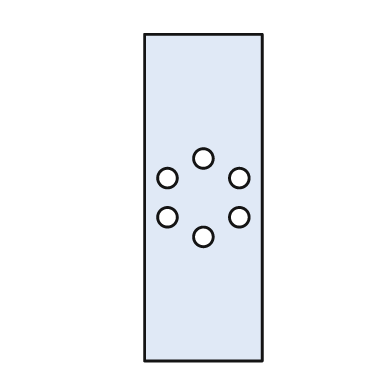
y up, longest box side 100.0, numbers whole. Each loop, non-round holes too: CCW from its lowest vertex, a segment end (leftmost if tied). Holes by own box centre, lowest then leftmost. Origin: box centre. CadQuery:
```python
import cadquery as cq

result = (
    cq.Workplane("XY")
    .moveTo(-18.0, -50.0)
    .lineTo(18.0, -50.0)
    .lineTo(18.0, 50.0)
    .lineTo(-18.0, 50.0)
    .close()
    .moveTo(0.0, -12.0)
    .circle(3.0)
    .moveTo(-11.0, -6.0)
    .circle(3.0)
    .moveTo(11.0, -6.0)
    .circle(3.0)
    .moveTo(-11.0, 6.0)
    .circle(3.0)
    .moveTo(11.0, 6.0)
    .circle(3.0)
    .moveTo(0.0, 12.0)
    .circle(3.0)
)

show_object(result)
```